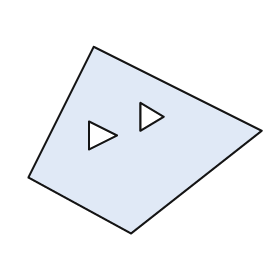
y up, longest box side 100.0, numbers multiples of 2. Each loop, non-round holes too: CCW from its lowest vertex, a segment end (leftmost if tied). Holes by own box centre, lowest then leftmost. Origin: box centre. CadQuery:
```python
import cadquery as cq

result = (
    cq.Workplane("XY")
    .moveTo(-6.0, -40.0)
    .lineTo(50.0, 4.0)
    .lineTo(-22.0, 40.0)
    .lineTo(-50.0, -16.0)
    .close()
    .moveTo(-24.0, -4.0)
    .lineTo(-12.0, 2.0)
    .lineTo(-24.0, 8.0)
    .close()
    .moveTo(-2.0, 4.0)
    .lineTo(8.0, 10.0)
    .lineTo(-2.0, 16.0)
    .close()
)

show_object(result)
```